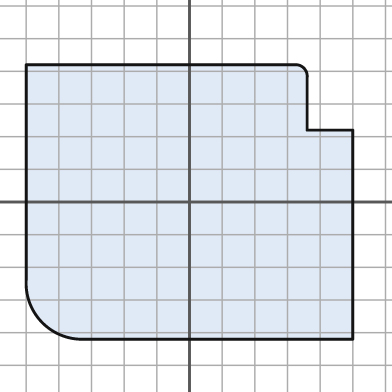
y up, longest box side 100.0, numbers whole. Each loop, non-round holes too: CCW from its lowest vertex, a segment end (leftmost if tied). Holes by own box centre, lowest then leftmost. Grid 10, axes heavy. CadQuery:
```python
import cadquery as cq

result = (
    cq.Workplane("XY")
    .moveTo(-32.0, -42.0)
    .lineTo(50.0, -42.0)
    .lineTo(50.0, 22.0)
    .lineTo(36.0, 22.0)
    .lineTo(36.0, 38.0)
    .threePointArc((35.0, 41.0), (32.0, 42.0))
    .lineTo(-50.0, 42.0)
    .lineTo(-50.0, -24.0)
    .threePointArc((-45.0, -37.0), (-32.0, -42.0))
    .close()
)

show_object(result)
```